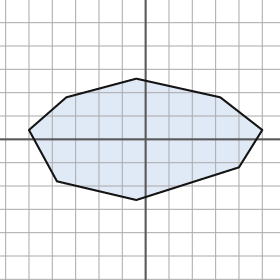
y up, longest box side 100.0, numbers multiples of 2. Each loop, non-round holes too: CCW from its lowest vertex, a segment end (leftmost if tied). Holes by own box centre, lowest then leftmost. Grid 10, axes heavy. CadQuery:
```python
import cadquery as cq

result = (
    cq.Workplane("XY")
    .moveTo(-4.0, -26.0)
    .lineTo(40.0, -12.0)
    .lineTo(50.0, 4.0)
    .lineTo(32.0, 18.0)
    .lineTo(-4.0, 26.0)
    .lineTo(-34.0, 18.0)
    .lineTo(-50.0, 4.0)
    .lineTo(-38.0, -18.0)
    .close()
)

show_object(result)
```